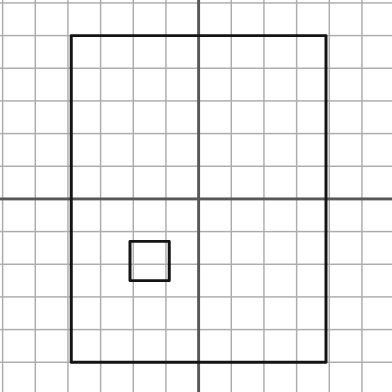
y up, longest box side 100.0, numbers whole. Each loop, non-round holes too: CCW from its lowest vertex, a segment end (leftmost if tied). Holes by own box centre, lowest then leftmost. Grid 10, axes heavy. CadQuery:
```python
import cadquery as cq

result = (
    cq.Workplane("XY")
    .moveTo(-39.0, -50.0)
    .lineTo(39.0, -50.0)
    .lineTo(39.0, 50.0)
    .lineTo(-39.0, 50.0)
    .close()
    .moveTo(-21.0, -25.0)
    .lineTo(-9.0, -25.0)
    .lineTo(-9.0, -13.0)
    .lineTo(-21.0, -13.0)
    .close()
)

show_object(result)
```